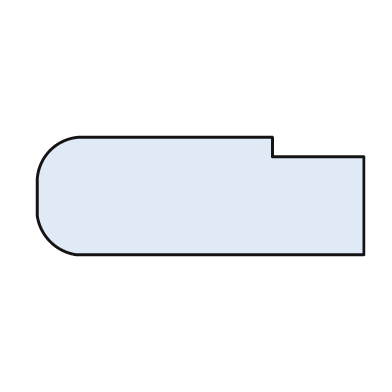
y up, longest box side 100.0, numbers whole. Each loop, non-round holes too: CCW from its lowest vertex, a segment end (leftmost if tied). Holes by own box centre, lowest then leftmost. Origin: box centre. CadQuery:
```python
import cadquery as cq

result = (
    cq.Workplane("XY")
    .moveTo(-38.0, -18.0)
    .lineTo(50.0, -18.0)
    .lineTo(50.0, 12.0)
    .lineTo(22.0, 12.0)
    .lineTo(22.0, 18.0)
    .lineTo(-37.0, 18.0)
    .threePointArc((-46.0, 14.0), (-50.0, 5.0))
    .lineTo(-50.0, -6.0)
    .threePointArc((-46.0, -14.0), (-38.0, -18.0))
    .close()
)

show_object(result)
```